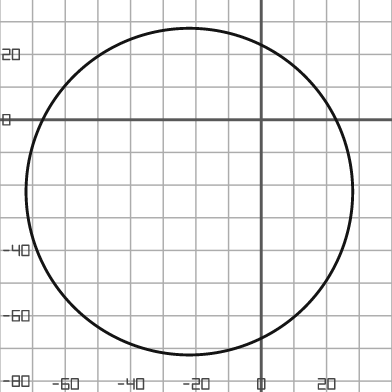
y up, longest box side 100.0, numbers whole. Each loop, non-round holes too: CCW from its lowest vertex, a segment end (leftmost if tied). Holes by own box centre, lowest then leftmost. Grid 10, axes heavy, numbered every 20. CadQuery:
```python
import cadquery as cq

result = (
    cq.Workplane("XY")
    .moveTo(-22.0, -22.0)
    .circle(50.0)
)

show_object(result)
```